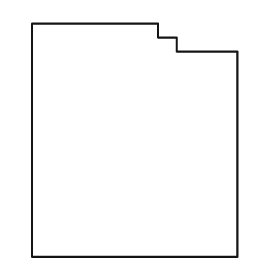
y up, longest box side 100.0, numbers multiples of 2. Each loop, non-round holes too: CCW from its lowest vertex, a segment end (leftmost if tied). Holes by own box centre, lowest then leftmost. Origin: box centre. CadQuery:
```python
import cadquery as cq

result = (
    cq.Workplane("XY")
    .moveTo(-44.0, -50.0)
    .lineTo(44.0, -50.0)
    .lineTo(44.0, 38.0)
    .lineTo(18.0, 38.0)
    .lineTo(18.0, 44.0)
    .lineTo(10.0, 44.0)
    .lineTo(10.0, 50.0)
    .lineTo(-44.0, 50.0)
    .close()
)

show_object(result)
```